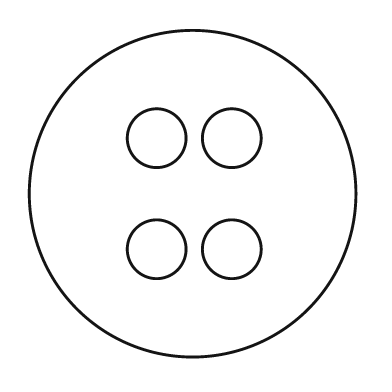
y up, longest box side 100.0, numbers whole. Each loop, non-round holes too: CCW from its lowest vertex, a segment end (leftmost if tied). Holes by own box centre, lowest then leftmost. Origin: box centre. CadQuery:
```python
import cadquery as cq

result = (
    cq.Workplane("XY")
    .moveTo(0.0, 0.0)
    .circle(50.0)
    .moveTo(-11.0, -17.0)
    .circle(9.0)
    .moveTo(12.0, -17.0)
    .circle(9.0)
    .moveTo(-11.0, 17.0)
    .circle(9.0)
    .moveTo(12.0, 17.0)
    .circle(9.0)
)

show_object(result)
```